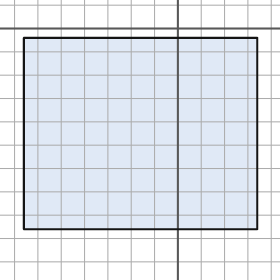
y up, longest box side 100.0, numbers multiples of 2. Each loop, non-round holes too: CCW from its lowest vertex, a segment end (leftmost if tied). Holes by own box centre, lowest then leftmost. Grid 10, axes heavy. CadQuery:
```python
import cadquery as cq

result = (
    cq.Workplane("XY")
    .moveTo(-66.0, -86.0)
    .lineTo(34.0, -86.0)
    .lineTo(34.0, -4.0)
    .lineTo(-66.0, -4.0)
    .close()
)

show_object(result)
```